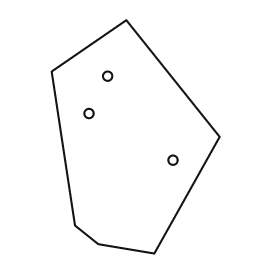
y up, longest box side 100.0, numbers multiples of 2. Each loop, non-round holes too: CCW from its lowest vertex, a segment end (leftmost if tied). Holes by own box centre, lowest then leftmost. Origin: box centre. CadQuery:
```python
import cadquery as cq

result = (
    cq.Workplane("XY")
    .moveTo(8.0, -50.0)
    .lineTo(36.0, 0.0)
    .lineTo(-4.0, 50.0)
    .lineTo(-36.0, 28.0)
    .lineTo(-26.0, -38.0)
    .lineTo(-16.0, -46.0)
    .close()
    .moveTo(16.0, -10.0)
    .circle(2.0)
    .moveTo(-20.0, 10.0)
    .circle(2.0)
    .moveTo(-12.0, 26.0)
    .circle(2.0)
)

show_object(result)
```